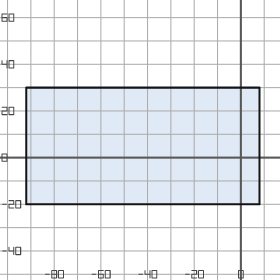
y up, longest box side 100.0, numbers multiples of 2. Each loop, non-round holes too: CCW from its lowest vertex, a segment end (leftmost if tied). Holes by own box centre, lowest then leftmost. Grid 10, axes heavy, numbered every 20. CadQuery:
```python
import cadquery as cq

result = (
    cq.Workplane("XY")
    .moveTo(-92.0, -20.0)
    .lineTo(8.0, -20.0)
    .lineTo(8.0, 30.0)
    .lineTo(-92.0, 30.0)
    .close()
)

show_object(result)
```